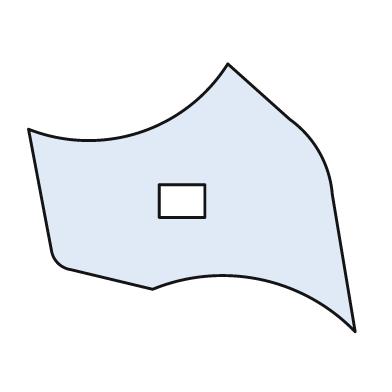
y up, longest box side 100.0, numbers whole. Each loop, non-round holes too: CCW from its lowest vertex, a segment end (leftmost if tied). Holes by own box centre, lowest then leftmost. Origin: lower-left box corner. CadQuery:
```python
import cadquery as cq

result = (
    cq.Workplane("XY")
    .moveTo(100.0, 0.0)
    .lineTo(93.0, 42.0)
    .threePointArc((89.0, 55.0), (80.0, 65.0))
    .lineTo(61.0, 82.0)
    .threePointArc((34.0, 61.0), (0.0, 62.0))
    .lineTo(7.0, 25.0)
    .threePointArc((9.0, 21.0), (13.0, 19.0))
    .lineTo(38.0, 13.0)
    .threePointArc((71.0, 16.0), (100.0, 0.0))
    .close()
    .moveTo(40.0, 35.0)
    .lineTo(54.0, 35.0)
    .lineTo(54.0, 45.0)
    .lineTo(40.0, 45.0)
    .close()
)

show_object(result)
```